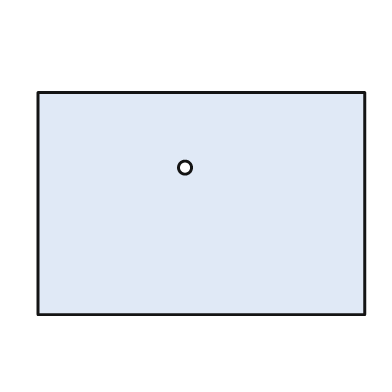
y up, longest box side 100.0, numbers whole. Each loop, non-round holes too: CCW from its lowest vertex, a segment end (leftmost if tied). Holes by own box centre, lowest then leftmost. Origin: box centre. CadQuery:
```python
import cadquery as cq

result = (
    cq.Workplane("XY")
    .moveTo(-50.0, -34.0)
    .lineTo(50.0, -34.0)
    .lineTo(50.0, 34.0)
    .lineTo(-50.0, 34.0)
    .close()
    .moveTo(-5.0, 11.0)
    .circle(2.0)
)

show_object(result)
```